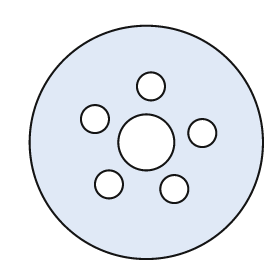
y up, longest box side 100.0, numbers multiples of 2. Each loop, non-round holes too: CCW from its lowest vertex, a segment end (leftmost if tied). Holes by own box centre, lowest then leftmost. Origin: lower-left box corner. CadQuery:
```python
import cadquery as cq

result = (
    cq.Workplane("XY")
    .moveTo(50.0, 50.0)
    .circle(50.0)
    .moveTo(62.0, 30.0)
    .circle(6.0)
    .moveTo(34.0, 32.0)
    .circle(6.0)
    .moveTo(50.0, 50.0)
    .circle(12.0)
    .moveTo(74.0, 54.0)
    .circle(6.0)
    .moveTo(28.0, 60.0)
    .circle(6.0)
    .moveTo(52.0, 74.0)
    .circle(6.0)
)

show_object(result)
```